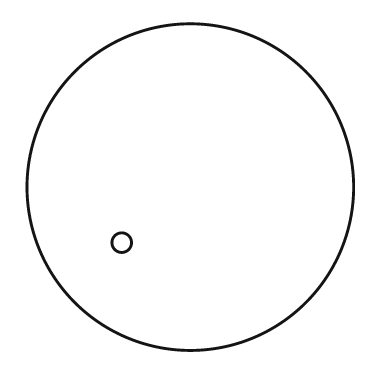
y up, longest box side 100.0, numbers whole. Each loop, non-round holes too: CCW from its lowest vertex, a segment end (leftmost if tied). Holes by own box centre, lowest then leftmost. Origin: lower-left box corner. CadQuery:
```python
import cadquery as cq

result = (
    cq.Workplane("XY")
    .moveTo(50.0, 50.0)
    .circle(50.0)
    .moveTo(29.0, 33.0)
    .circle(3.0)
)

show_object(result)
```